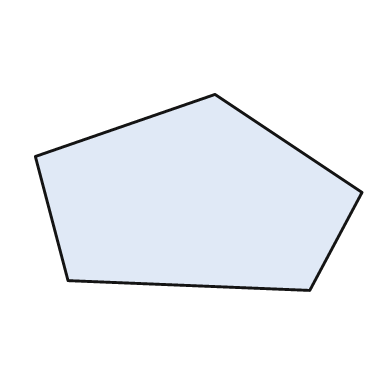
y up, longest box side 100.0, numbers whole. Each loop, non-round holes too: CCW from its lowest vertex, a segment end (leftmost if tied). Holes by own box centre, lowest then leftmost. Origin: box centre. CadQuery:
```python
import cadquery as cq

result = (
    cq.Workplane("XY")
    .moveTo(34.0, -30.0)
    .lineTo(50.0, 0.0)
    .lineTo(5.0, 30.0)
    .lineTo(-50.0, 11.0)
    .lineTo(-40.0, -27.0)
    .close()
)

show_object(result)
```